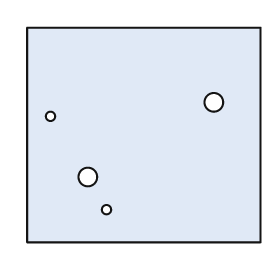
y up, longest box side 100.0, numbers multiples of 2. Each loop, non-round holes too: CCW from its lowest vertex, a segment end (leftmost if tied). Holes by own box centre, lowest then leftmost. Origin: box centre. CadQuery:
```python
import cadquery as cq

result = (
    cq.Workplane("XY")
    .moveTo(-50.0, -46.0)
    .lineTo(50.0, -46.0)
    .lineTo(50.0, 46.0)
    .lineTo(-50.0, 46.0)
    .close()
    .moveTo(-16.0, -32.0)
    .circle(2.0)
    .moveTo(-24.0, -18.0)
    .circle(4.0)
    .moveTo(-40.0, 8.0)
    .circle(2.0)
    .moveTo(30.0, 14.0)
    .circle(4.0)
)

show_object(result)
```